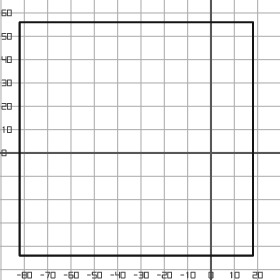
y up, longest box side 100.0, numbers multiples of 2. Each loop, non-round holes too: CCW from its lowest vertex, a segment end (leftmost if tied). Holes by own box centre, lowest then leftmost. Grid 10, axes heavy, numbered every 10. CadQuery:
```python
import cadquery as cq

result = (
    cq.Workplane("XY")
    .moveTo(-82.0, -44.0)
    .lineTo(18.0, -44.0)
    .lineTo(18.0, 56.0)
    .lineTo(-82.0, 56.0)
    .close()
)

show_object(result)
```